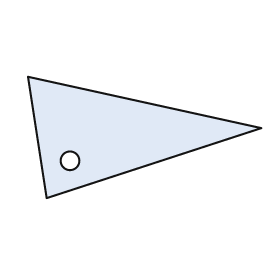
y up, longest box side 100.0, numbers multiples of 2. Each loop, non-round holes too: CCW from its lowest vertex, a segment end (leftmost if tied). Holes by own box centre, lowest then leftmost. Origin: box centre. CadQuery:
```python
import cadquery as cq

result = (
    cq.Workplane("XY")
    .moveTo(-42.0, -26.0)
    .lineTo(50.0, 4.0)
    .lineTo(-50.0, 26.0)
    .close()
    .moveTo(-32.0, -10.0)
    .circle(4.0)
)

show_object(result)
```